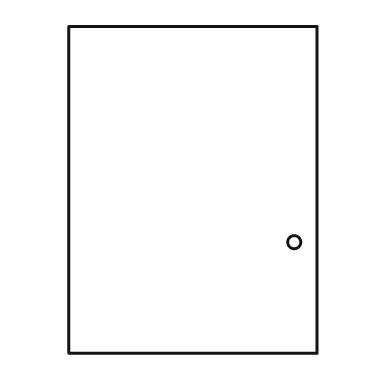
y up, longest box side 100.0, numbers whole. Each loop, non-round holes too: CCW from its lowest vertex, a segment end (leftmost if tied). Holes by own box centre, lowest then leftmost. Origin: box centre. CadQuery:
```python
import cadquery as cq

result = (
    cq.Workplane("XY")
    .moveTo(-38.0, -50.0)
    .lineTo(38.0, -50.0)
    .lineTo(38.0, 50.0)
    .lineTo(-38.0, 50.0)
    .close()
    .moveTo(31.0, -16.0)
    .circle(2.0)
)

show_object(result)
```